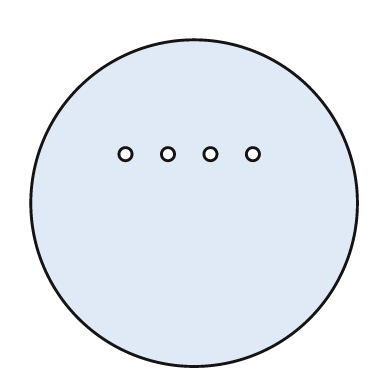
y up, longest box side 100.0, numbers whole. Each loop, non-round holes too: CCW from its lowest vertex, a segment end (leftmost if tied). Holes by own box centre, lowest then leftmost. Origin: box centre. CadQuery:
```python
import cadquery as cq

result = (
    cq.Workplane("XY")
    .moveTo(0.0, 0.0)
    .circle(50.0)
    .moveTo(-21.0, 15.0)
    .circle(2.0)
    .moveTo(-8.0, 15.0)
    .circle(2.0)
    .moveTo(5.0, 15.0)
    .circle(2.0)
    .moveTo(18.0, 15.0)
    .circle(2.0)
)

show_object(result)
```